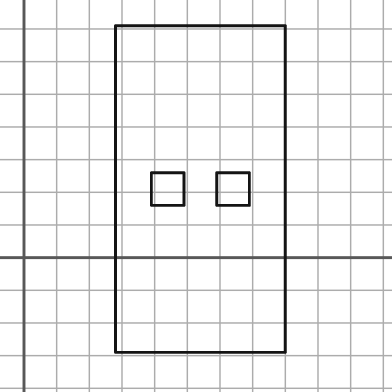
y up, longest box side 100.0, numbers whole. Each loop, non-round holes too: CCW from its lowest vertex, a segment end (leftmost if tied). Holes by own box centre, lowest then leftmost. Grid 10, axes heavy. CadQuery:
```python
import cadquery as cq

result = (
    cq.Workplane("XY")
    .moveTo(28.0, -29.0)
    .lineTo(80.0, -29.0)
    .lineTo(80.0, 71.0)
    .lineTo(28.0, 71.0)
    .close()
    .moveTo(39.0, 16.0)
    .lineTo(49.0, 16.0)
    .lineTo(49.0, 26.0)
    .lineTo(39.0, 26.0)
    .close()
    .moveTo(59.0, 16.0)
    .lineTo(69.0, 16.0)
    .lineTo(69.0, 26.0)
    .lineTo(59.0, 26.0)
    .close()
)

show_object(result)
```